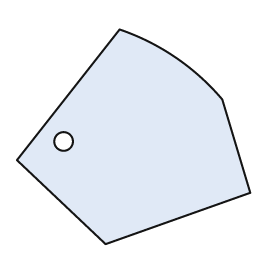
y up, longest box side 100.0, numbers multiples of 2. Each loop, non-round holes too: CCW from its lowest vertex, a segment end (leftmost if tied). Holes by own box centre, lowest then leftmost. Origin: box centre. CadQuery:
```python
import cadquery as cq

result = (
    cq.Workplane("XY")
    .moveTo(-12.0, -46.0)
    .lineTo(50.0, -24.0)
    .lineTo(38.0, 16.0)
    .threePointArc((18.0, 34.0), (-6.0, 46.0))
    .lineTo(-50.0, -10.0)
    .close()
    .moveTo(-30.0, -2.0)
    .circle(4.0)
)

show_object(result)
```